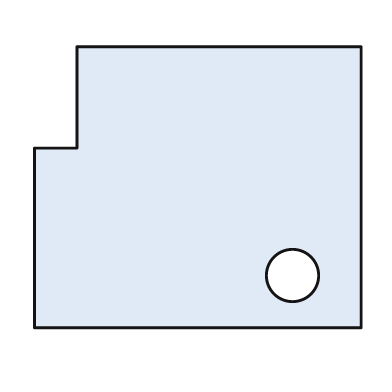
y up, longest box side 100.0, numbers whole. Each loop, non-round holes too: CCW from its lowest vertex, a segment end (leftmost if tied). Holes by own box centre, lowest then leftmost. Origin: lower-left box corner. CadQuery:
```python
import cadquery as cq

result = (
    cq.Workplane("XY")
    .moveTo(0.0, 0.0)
    .lineTo(100.0, 0.0)
    .lineTo(100.0, 86.0)
    .lineTo(13.0, 86.0)
    .lineTo(13.0, 55.0)
    .lineTo(0.0, 55.0)
    .close()
    .moveTo(79.0, 16.0)
    .circle(8.0)
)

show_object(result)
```